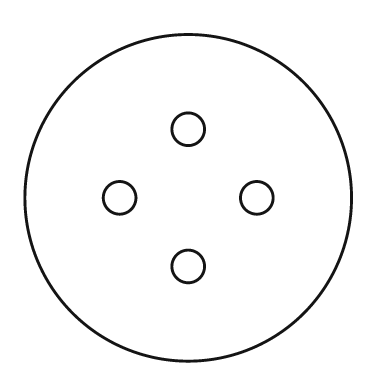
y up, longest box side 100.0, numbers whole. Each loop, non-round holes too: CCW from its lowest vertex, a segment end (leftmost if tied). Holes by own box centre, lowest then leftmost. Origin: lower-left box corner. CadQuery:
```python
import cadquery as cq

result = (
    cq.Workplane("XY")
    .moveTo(50.0, 50.0)
    .circle(50.0)
    .moveTo(50.0, 29.0)
    .circle(5.0)
    .moveTo(29.0, 50.0)
    .circle(5.0)
    .moveTo(71.0, 50.0)
    .circle(5.0)
    .moveTo(50.0, 71.0)
    .circle(5.0)
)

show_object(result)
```